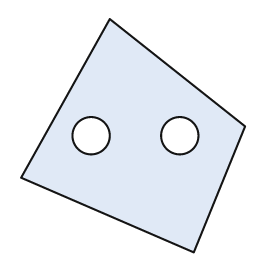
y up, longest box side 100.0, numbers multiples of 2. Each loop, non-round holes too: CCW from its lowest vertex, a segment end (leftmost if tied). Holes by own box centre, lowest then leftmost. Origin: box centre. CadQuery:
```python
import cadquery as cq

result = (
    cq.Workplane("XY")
    .moveTo(26.0, -50.0)
    .lineTo(48.0, 4.0)
    .lineTo(-10.0, 50.0)
    .lineTo(-48.0, -18.0)
    .close()
    .moveTo(-18.0, 0.0)
    .circle(8.0)
    .moveTo(20.0, 0.0)
    .circle(8.0)
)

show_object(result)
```